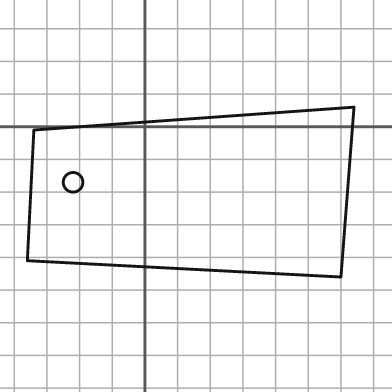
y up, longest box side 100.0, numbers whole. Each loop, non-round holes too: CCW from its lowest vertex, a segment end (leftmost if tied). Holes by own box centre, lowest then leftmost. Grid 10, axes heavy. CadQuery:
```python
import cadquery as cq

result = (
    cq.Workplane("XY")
    .moveTo(60.0, -46.0)
    .lineTo(64.0, 6.0)
    .lineTo(-34.0, -1.0)
    .lineTo(-36.0, -41.0)
    .close()
    .moveTo(-22.0, -17.0)
    .circle(3.0)
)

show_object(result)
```